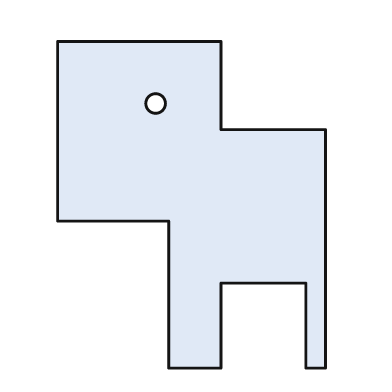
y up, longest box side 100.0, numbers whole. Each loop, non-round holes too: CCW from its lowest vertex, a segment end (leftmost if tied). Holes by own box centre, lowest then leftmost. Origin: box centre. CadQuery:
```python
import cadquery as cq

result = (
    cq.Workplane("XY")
    .moveTo(-7.0, -50.0)
    .lineTo(9.0, -50.0)
    .lineTo(9.0, -24.0)
    .lineTo(35.0, -24.0)
    .lineTo(35.0, -50.0)
    .lineTo(41.0, -50.0)
    .lineTo(41.0, 23.0)
    .lineTo(9.0, 23.0)
    .lineTo(9.0, 50.0)
    .lineTo(-41.0, 50.0)
    .lineTo(-41.0, -5.0)
    .lineTo(-7.0, -5.0)
    .close()
    .moveTo(-11.0, 31.0)
    .circle(3.0)
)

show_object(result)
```